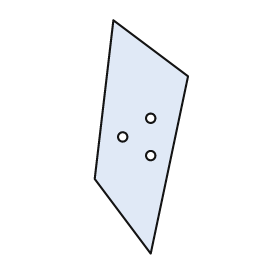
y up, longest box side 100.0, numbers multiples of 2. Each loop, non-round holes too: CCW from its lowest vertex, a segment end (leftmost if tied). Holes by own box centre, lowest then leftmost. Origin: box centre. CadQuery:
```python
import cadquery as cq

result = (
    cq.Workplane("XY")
    .moveTo(4.0, -50.0)
    .lineTo(20.0, 26.0)
    .lineTo(-12.0, 50.0)
    .lineTo(-20.0, -18.0)
    .close()
    .moveTo(4.0, -8.0)
    .circle(2.0)
    .moveTo(-8.0, 0.0)
    .circle(2.0)
    .moveTo(4.0, 8.0)
    .circle(2.0)
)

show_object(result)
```